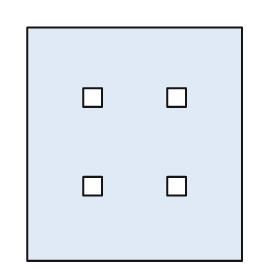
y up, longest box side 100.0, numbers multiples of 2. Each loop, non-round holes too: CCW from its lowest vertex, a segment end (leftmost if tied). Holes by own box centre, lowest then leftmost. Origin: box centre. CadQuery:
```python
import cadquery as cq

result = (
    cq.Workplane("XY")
    .moveTo(-46.0, -50.0)
    .lineTo(46.0, -50.0)
    .lineTo(46.0, 50.0)
    .lineTo(-46.0, 50.0)
    .close()
    .moveTo(-22.0, -22.0)
    .lineTo(-14.0, -22.0)
    .lineTo(-14.0, -14.0)
    .lineTo(-22.0, -14.0)
    .close()
    .moveTo(14.0, -22.0)
    .lineTo(22.0, -22.0)
    .lineTo(22.0, -14.0)
    .lineTo(14.0, -14.0)
    .close()
    .moveTo(-22.0, 16.0)
    .lineTo(-14.0, 16.0)
    .lineTo(-14.0, 24.0)
    .lineTo(-22.0, 24.0)
    .close()
    .moveTo(14.0, 16.0)
    .lineTo(22.0, 16.0)
    .lineTo(22.0, 24.0)
    .lineTo(14.0, 24.0)
    .close()
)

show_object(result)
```